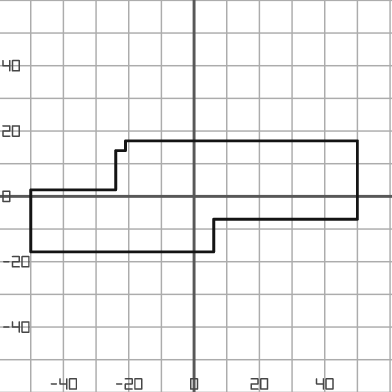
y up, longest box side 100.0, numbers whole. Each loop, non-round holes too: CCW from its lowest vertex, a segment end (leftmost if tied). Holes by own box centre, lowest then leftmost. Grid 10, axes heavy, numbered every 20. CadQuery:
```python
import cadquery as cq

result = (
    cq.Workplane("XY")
    .moveTo(-50.0, -17.0)
    .lineTo(6.0, -17.0)
    .lineTo(6.0, -7.0)
    .lineTo(50.0, -7.0)
    .lineTo(50.0, 17.0)
    .lineTo(-21.0, 17.0)
    .lineTo(-21.0, 14.0)
    .lineTo(-24.0, 14.0)
    .lineTo(-24.0, 2.0)
    .lineTo(-50.0, 2.0)
    .close()
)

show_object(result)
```